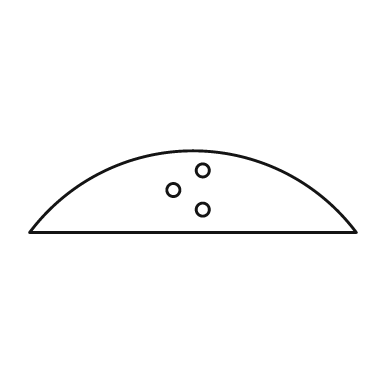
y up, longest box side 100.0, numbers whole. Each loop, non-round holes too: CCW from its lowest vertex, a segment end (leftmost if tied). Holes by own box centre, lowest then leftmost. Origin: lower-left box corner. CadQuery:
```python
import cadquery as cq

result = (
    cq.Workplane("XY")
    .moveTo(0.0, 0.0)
    .lineTo(100.0, 0.0)
    .threePointArc((50.0, 25.0), (0.0, 0.0))
    .close()
    .moveTo(53.0, 7.0)
    .circle(2.0)
    .moveTo(44.0, 13.0)
    .circle(2.0)
    .moveTo(53.0, 19.0)
    .circle(2.0)
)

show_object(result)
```